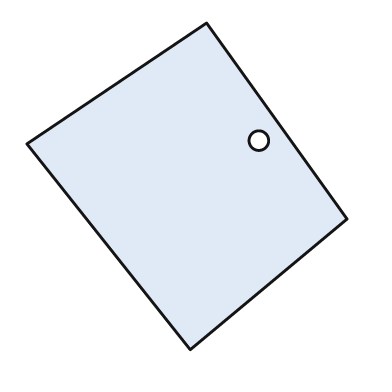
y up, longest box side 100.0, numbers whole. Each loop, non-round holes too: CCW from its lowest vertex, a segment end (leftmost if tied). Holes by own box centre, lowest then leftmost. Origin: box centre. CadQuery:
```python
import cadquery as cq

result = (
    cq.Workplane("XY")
    .moveTo(1.0, -50.0)
    .lineTo(49.0, -10.0)
    .lineTo(6.0, 50.0)
    .lineTo(-49.0, 13.0)
    .close()
    .moveTo(22.0, 14.0)
    .circle(3.0)
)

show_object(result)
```